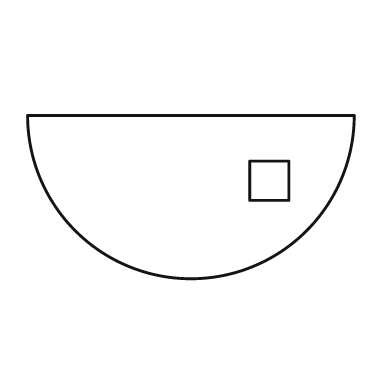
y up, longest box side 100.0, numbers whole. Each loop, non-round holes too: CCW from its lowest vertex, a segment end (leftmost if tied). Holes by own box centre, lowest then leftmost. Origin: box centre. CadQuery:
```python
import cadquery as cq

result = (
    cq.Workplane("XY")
    .moveTo(-50.0, 25.0)
    .threePointArc((0.0, -25.0), (50.0, 25.0))
    .close()
    .moveTo(18.0, -1.0)
    .lineTo(30.0, -1.0)
    .lineTo(30.0, 11.0)
    .lineTo(18.0, 11.0)
    .close()
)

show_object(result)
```